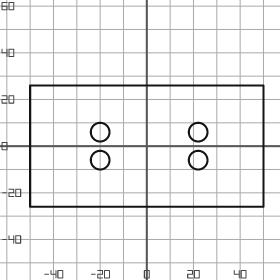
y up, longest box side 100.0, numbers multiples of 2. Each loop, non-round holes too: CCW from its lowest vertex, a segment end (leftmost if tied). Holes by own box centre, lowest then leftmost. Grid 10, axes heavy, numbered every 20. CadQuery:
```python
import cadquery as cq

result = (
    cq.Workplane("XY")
    .moveTo(-50.0, -26.0)
    .lineTo(50.0, -26.0)
    .lineTo(50.0, 26.0)
    .lineTo(-50.0, 26.0)
    .close()
    .moveTo(-20.0, -6.0)
    .circle(4.0)
    .moveTo(22.0, -6.0)
    .circle(4.0)
    .moveTo(-20.0, 6.0)
    .circle(4.0)
    .moveTo(22.0, 6.0)
    .circle(4.0)
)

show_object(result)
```